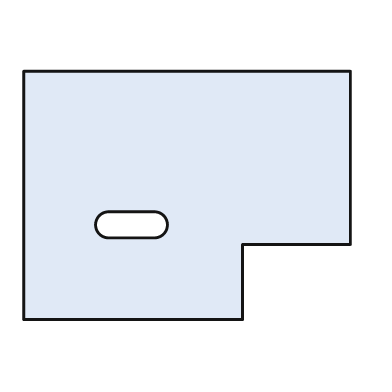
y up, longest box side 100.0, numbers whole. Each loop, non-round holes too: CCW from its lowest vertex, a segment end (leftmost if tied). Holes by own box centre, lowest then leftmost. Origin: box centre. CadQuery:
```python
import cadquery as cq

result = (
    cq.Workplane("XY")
    .moveTo(-50.0, -38.0)
    .lineTo(17.0, -38.0)
    .lineTo(17.0, -15.0)
    .lineTo(50.0, -15.0)
    .lineTo(50.0, 38.0)
    .lineTo(-50.0, 38.0)
    .close()
    .moveTo(-24.0, -13.0)
    .lineTo(-10.0, -13.0)
    .threePointArc((-6.0, -9.0), (-10.0, -5.0))
    .lineTo(-24.0, -5.0)
    .threePointArc((-28.0, -9.0), (-24.0, -13.0))
    .close()
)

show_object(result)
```